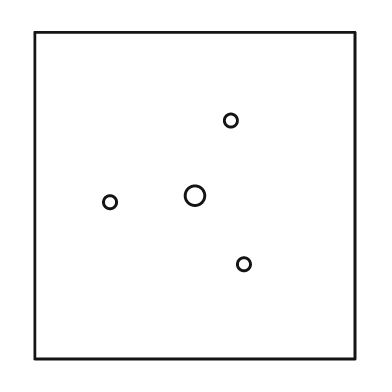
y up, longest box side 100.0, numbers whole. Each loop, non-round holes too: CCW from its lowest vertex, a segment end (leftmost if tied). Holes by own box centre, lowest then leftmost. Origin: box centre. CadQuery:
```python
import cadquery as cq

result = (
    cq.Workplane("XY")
    .moveTo(-49.0, -50.0)
    .lineTo(49.0, -50.0)
    .lineTo(49.0, 50.0)
    .lineTo(-49.0, 50.0)
    .close()
    .moveTo(15.0, -21.0)
    .circle(2.0)
    .moveTo(-26.0, -2.0)
    .circle(2.0)
    .moveTo(0.0, 0.0)
    .circle(3.0)
    .moveTo(11.0, 23.0)
    .circle(2.0)
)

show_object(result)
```